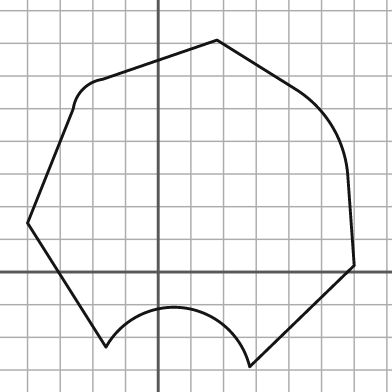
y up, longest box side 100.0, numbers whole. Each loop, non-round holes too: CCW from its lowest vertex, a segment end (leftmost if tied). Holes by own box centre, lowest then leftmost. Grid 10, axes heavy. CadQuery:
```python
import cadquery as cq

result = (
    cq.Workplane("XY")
    .moveTo(28.0, -29.0)
    .lineTo(60.0, 2.0)
    .lineTo(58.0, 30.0)
    .threePointArc((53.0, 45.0), (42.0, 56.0))
    .lineTo(18.0, 71.0)
    .lineTo(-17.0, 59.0)
    .threePointArc((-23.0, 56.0), (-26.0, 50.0))
    .lineTo(-40.0, 15.0)
    .lineTo(-16.0, -23.0)
    .threePointArc((8.0, -11.0), (28.0, -29.0))
    .close()
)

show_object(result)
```